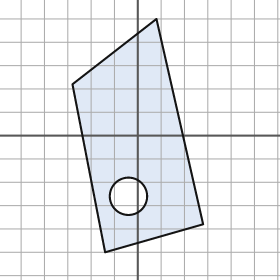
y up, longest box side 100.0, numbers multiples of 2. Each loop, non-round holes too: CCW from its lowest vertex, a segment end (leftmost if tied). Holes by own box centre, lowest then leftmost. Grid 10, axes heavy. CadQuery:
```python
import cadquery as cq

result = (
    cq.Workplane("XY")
    .moveTo(-14.0, -50.0)
    .lineTo(28.0, -38.0)
    .lineTo(8.0, 50.0)
    .lineTo(-28.0, 22.0)
    .close()
    .moveTo(-4.0, -26.0)
    .circle(8.0)
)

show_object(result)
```